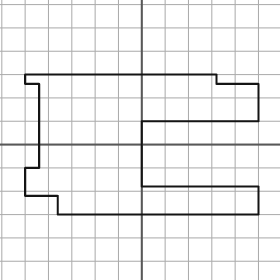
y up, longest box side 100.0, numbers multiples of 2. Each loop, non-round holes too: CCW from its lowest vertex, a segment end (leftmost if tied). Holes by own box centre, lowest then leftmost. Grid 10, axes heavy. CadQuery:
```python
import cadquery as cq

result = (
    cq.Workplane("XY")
    .moveTo(-36.0, -30.0)
    .lineTo(50.0, -30.0)
    .lineTo(50.0, -18.0)
    .lineTo(0.0, -18.0)
    .lineTo(0.0, 10.0)
    .lineTo(50.0, 10.0)
    .lineTo(50.0, 26.0)
    .lineTo(32.0, 26.0)
    .lineTo(32.0, 30.0)
    .lineTo(-50.0, 30.0)
    .lineTo(-50.0, 26.0)
    .lineTo(-44.0, 26.0)
    .lineTo(-44.0, -10.0)
    .lineTo(-50.0, -10.0)
    .lineTo(-50.0, -22.0)
    .lineTo(-36.0, -22.0)
    .close()
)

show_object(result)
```